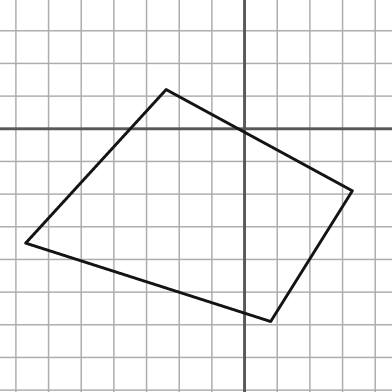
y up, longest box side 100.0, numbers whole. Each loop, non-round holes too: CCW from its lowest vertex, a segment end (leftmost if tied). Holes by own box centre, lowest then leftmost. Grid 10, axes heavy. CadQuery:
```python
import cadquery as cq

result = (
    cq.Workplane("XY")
    .moveTo(8.0, -59.0)
    .lineTo(33.0, -19.0)
    .lineTo(-24.0, 12.0)
    .lineTo(-67.0, -35.0)
    .close()
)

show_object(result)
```